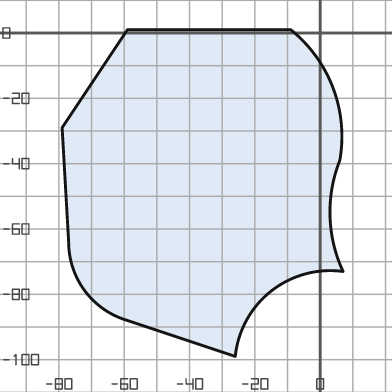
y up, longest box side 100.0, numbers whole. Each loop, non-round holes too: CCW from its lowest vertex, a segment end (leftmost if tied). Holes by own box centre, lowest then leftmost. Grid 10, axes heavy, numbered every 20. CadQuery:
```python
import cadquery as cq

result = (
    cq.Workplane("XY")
    .moveTo(-26.0, -99.0)
    .threePointArc((-15.0, -79.0), (7.0, -73.0))
    .threePointArc((3.0, -56.0), (6.0, -39.0))
    .threePointArc((4.0, -17.0), (-9.0, 1.0))
    .lineTo(-59.0, 1.0)
    .lineTo(-79.0, -29.0)
    .lineTo(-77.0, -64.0)
    .threePointArc((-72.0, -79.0), (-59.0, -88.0))
    .close()
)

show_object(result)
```